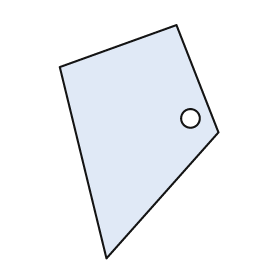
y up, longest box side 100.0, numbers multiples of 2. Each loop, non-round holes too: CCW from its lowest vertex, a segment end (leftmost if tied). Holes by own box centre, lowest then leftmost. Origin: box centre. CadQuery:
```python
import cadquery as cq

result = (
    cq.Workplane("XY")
    .moveTo(-14.0, -50.0)
    .lineTo(34.0, 4.0)
    .lineTo(16.0, 50.0)
    .lineTo(-34.0, 32.0)
    .close()
    .moveTo(22.0, 10.0)
    .circle(4.0)
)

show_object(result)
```